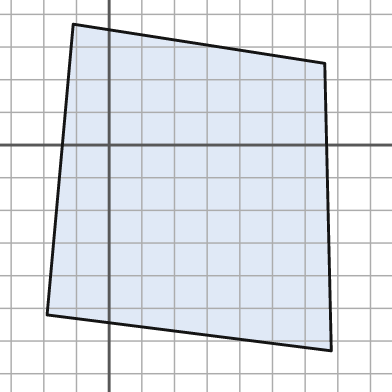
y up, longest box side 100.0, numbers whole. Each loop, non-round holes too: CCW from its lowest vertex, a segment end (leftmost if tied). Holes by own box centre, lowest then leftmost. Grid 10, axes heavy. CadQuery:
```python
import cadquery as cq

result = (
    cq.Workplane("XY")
    .moveTo(68.0, -63.0)
    .lineTo(66.0, 25.0)
    .lineTo(-11.0, 37.0)
    .lineTo(-19.0, -52.0)
    .close()
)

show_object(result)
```